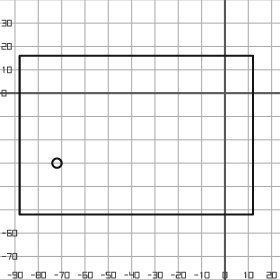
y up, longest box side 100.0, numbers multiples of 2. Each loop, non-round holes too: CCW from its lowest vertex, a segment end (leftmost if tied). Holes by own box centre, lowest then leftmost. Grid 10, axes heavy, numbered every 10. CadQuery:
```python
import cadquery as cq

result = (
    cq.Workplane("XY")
    .moveTo(-88.0, -52.0)
    .lineTo(12.0, -52.0)
    .lineTo(12.0, 16.0)
    .lineTo(-88.0, 16.0)
    .close()
    .moveTo(-72.0, -30.0)
    .circle(2.0)
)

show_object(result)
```